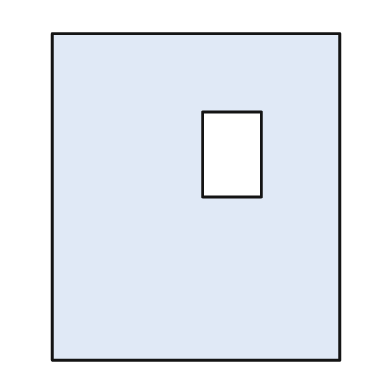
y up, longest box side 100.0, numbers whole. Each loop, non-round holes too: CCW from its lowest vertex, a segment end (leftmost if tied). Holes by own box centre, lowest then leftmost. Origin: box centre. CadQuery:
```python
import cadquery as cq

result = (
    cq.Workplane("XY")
    .moveTo(-44.0, -50.0)
    .lineTo(44.0, -50.0)
    .lineTo(44.0, 50.0)
    .lineTo(-44.0, 50.0)
    .close()
    .moveTo(2.0, 0.0)
    .lineTo(20.0, 0.0)
    .lineTo(20.0, 26.0)
    .lineTo(2.0, 26.0)
    .close()
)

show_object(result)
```